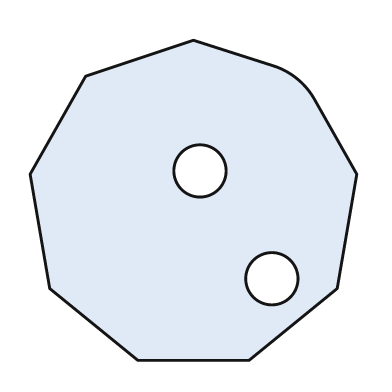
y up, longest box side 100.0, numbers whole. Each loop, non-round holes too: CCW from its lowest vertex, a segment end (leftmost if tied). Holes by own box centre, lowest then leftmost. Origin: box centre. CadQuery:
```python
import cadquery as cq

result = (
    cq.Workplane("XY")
    .moveTo(-17.0, -49.0)
    .lineTo(17.0, -49.0)
    .lineTo(44.0, -27.0)
    .lineTo(50.0, 8.0)
    .lineTo(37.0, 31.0)
    .threePointArc((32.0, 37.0), (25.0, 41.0))
    .lineTo(0.0, 49.0)
    .lineTo(-33.0, 38.0)
    .lineTo(-50.0, 8.0)
    .lineTo(-44.0, -27.0)
    .close()
    .moveTo(24.0, -24.0)
    .circle(8.0)
    .moveTo(2.0, 9.0)
    .circle(8.0)
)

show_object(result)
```